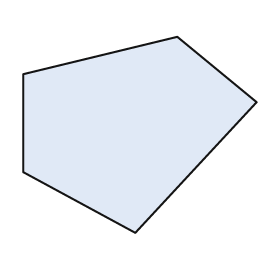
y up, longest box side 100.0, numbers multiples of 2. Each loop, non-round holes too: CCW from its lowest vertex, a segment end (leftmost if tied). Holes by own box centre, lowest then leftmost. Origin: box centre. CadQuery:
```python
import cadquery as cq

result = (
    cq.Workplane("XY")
    .moveTo(-2.0, -42.0)
    .lineTo(50.0, 14.0)
    .lineTo(16.0, 42.0)
    .lineTo(-50.0, 26.0)
    .lineTo(-50.0, -16.0)
    .close()
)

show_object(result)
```